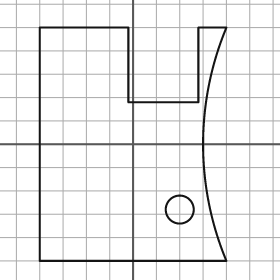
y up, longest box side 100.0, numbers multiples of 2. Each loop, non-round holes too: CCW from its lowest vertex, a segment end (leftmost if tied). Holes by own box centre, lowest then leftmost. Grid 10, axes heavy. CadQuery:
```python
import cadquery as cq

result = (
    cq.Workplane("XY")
    .moveTo(-40.0, -50.0)
    .lineTo(40.0, -50.0)
    .threePointArc((30.0, 0.0), (40.0, 50.0))
    .lineTo(28.0, 50.0)
    .lineTo(28.0, 18.0)
    .lineTo(-2.0, 18.0)
    .lineTo(-2.0, 50.0)
    .lineTo(-40.0, 50.0)
    .close()
    .moveTo(20.0, -28.0)
    .circle(6.0)
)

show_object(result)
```